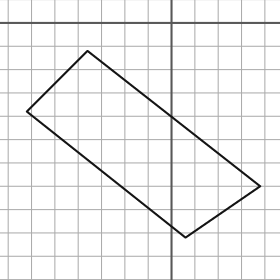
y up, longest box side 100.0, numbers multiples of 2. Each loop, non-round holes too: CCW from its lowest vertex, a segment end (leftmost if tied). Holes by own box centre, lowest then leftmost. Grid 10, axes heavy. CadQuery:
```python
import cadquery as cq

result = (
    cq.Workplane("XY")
    .moveTo(6.0, -92.0)
    .lineTo(38.0, -70.0)
    .lineTo(-36.0, -12.0)
    .lineTo(-62.0, -38.0)
    .close()
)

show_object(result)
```